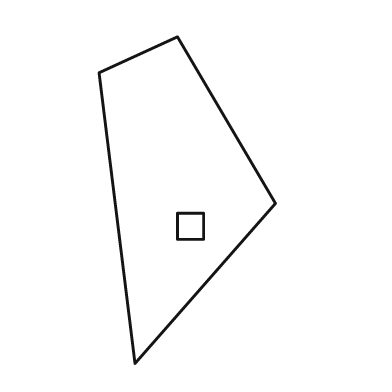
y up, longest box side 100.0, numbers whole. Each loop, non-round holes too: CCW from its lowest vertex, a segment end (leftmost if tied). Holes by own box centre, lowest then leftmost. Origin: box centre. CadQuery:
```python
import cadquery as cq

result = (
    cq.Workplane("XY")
    .moveTo(-16.0, -50.0)
    .lineTo(27.0, -1.0)
    .lineTo(-3.0, 50.0)
    .lineTo(-27.0, 39.0)
    .close()
    .moveTo(-3.0, -12.0)
    .lineTo(5.0, -12.0)
    .lineTo(5.0, -4.0)
    .lineTo(-3.0, -4.0)
    .close()
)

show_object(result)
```